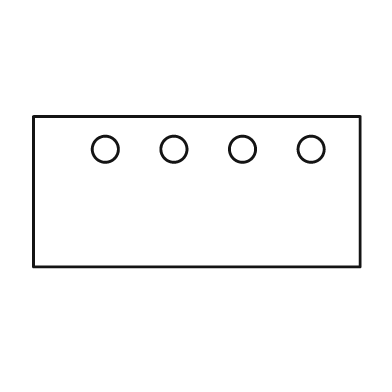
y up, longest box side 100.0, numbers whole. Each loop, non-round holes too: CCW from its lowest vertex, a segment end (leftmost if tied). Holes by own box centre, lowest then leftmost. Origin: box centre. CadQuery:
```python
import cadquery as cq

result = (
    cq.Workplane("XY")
    .moveTo(-50.0, -23.0)
    .lineTo(50.0, -23.0)
    .lineTo(50.0, 23.0)
    .lineTo(-50.0, 23.0)
    .close()
    .moveTo(-28.0, 13.0)
    .circle(4.0)
    .moveTo(-7.0, 13.0)
    .circle(4.0)
    .moveTo(14.0, 13.0)
    .circle(4.0)
    .moveTo(35.0, 13.0)
    .circle(4.0)
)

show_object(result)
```